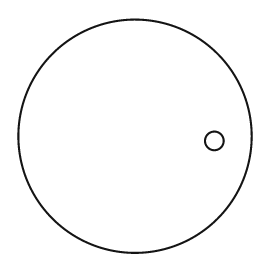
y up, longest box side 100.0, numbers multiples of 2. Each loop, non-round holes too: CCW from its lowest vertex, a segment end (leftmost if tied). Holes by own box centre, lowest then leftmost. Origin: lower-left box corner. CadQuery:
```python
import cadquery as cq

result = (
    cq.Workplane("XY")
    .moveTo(50.0, 50.0)
    .circle(50.0)
    .moveTo(84.0, 48.0)
    .circle(4.0)
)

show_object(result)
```